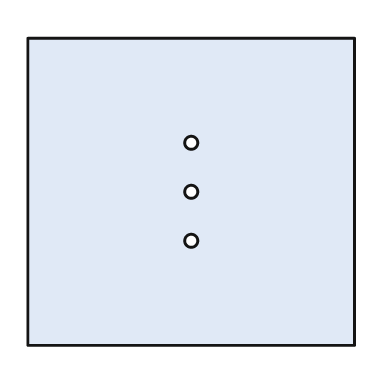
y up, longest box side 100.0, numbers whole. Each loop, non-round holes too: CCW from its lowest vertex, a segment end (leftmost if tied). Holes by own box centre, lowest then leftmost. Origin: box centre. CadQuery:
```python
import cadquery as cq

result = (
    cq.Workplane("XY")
    .moveTo(-50.0, -47.0)
    .lineTo(50.0, -47.0)
    .lineTo(50.0, 47.0)
    .lineTo(-50.0, 47.0)
    .close()
    .moveTo(0.0, -15.0)
    .circle(2.0)
    .moveTo(0.0, 0.0)
    .circle(2.0)
    .moveTo(0.0, 15.0)
    .circle(2.0)
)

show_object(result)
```